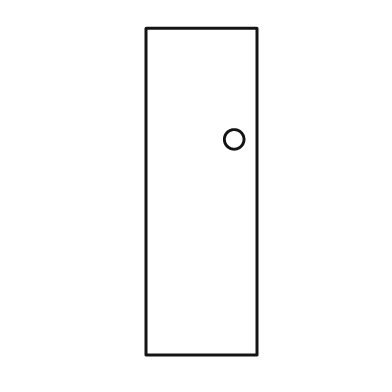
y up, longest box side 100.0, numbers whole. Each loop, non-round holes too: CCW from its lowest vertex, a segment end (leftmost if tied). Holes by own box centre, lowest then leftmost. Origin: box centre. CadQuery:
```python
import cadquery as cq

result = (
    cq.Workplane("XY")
    .moveTo(-17.0, -50.0)
    .lineTo(17.0, -50.0)
    .lineTo(17.0, 50.0)
    .lineTo(-17.0, 50.0)
    .close()
    .moveTo(10.0, 16.0)
    .circle(3.0)
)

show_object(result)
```